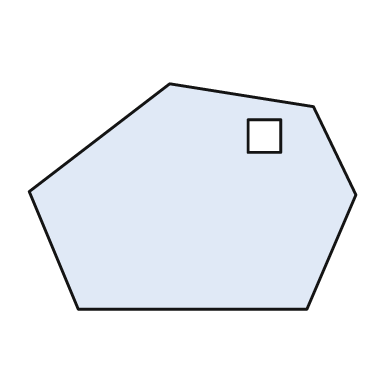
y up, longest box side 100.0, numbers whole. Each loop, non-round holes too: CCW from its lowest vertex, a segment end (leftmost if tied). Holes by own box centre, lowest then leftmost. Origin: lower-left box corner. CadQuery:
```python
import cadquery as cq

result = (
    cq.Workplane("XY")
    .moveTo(15.0, 0.0)
    .lineTo(85.0, 0.0)
    .lineTo(100.0, 35.0)
    .lineTo(87.0, 62.0)
    .lineTo(43.0, 69.0)
    .lineTo(0.0, 36.0)
    .close()
    .moveTo(67.0, 48.0)
    .lineTo(77.0, 48.0)
    .lineTo(77.0, 58.0)
    .lineTo(67.0, 58.0)
    .close()
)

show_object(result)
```